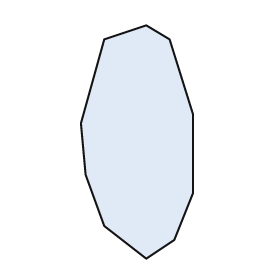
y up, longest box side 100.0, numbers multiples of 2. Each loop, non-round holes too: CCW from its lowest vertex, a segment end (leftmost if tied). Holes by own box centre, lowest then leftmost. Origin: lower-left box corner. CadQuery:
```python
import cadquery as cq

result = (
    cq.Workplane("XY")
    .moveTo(28.0, 0.0)
    .lineTo(40.0, 8.0)
    .lineTo(48.0, 28.0)
    .lineTo(48.0, 62.0)
    .lineTo(38.0, 94.0)
    .lineTo(28.0, 100.0)
    .lineTo(10.0, 94.0)
    .lineTo(0.0, 58.0)
    .lineTo(2.0, 36.0)
    .lineTo(10.0, 14.0)
    .close()
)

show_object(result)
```